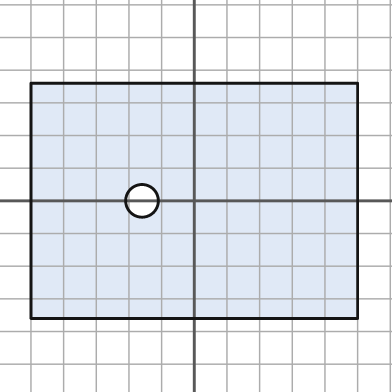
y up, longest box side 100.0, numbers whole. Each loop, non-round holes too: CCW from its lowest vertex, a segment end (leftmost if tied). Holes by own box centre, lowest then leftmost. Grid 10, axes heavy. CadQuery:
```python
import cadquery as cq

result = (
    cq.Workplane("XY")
    .moveTo(-50.0, -36.0)
    .lineTo(50.0, -36.0)
    .lineTo(50.0, 36.0)
    .lineTo(-50.0, 36.0)
    .close()
    .moveTo(-16.0, 0.0)
    .circle(5.0)
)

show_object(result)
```